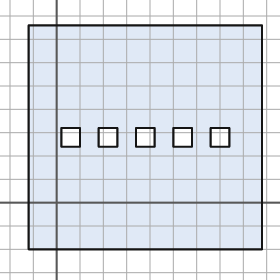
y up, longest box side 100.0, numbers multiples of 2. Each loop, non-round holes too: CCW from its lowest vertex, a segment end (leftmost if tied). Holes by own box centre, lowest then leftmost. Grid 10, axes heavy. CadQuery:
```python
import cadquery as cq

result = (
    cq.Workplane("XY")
    .moveTo(-12.0, -20.0)
    .lineTo(88.0, -20.0)
    .lineTo(88.0, 76.0)
    .lineTo(-12.0, 76.0)
    .close()
    .moveTo(2.0, 24.0)
    .lineTo(10.0, 24.0)
    .lineTo(10.0, 32.0)
    .lineTo(2.0, 32.0)
    .close()
    .moveTo(18.0, 24.0)
    .lineTo(26.0, 24.0)
    .lineTo(26.0, 32.0)
    .lineTo(18.0, 32.0)
    .close()
    .moveTo(34.0, 24.0)
    .lineTo(42.0, 24.0)
    .lineTo(42.0, 32.0)
    .lineTo(34.0, 32.0)
    .close()
    .moveTo(50.0, 24.0)
    .lineTo(58.0, 24.0)
    .lineTo(58.0, 32.0)
    .lineTo(50.0, 32.0)
    .close()
    .moveTo(66.0, 24.0)
    .lineTo(74.0, 24.0)
    .lineTo(74.0, 32.0)
    .lineTo(66.0, 32.0)
    .close()
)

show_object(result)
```